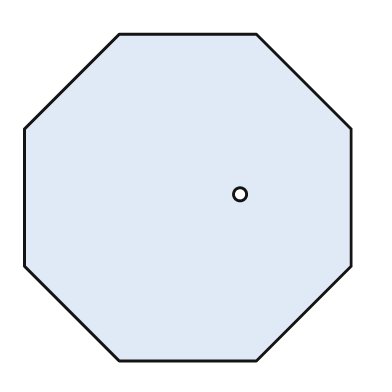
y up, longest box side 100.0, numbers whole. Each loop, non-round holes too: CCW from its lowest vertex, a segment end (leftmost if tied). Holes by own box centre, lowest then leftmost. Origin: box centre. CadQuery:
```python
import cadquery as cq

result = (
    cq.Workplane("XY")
    .moveTo(-21.0, -50.0)
    .lineTo(21.0, -50.0)
    .lineTo(50.0, -21.0)
    .lineTo(50.0, 21.0)
    .lineTo(21.0, 50.0)
    .lineTo(-21.0, 50.0)
    .lineTo(-50.0, 21.0)
    .lineTo(-50.0, -21.0)
    .close()
    .moveTo(16.0, 1.0)
    .circle(2.0)
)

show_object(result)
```